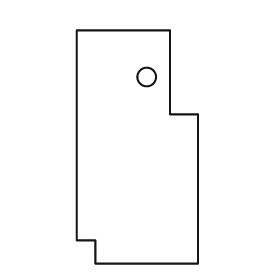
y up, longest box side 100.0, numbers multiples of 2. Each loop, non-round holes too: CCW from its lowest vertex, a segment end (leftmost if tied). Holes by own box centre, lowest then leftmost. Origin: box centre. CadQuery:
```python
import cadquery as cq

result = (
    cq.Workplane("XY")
    .moveTo(-18.0, -50.0)
    .lineTo(26.0, -50.0)
    .lineTo(26.0, 14.0)
    .lineTo(14.0, 14.0)
    .lineTo(14.0, 50.0)
    .lineTo(-26.0, 50.0)
    .lineTo(-26.0, -40.0)
    .lineTo(-18.0, -40.0)
    .close()
    .moveTo(4.0, 30.0)
    .circle(4.0)
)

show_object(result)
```